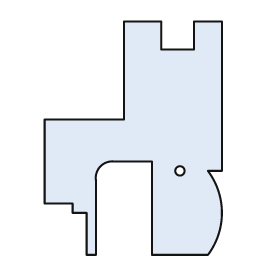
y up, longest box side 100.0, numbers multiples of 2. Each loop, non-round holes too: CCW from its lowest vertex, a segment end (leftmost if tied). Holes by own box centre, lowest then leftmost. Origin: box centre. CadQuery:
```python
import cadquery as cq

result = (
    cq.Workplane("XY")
    .moveTo(-20.0, -50.0)
    .lineTo(-16.0, -50.0)
    .lineTo(-16.0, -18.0)
    .threePointArc((-14.0, -12.0), (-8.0, -10.0))
    .lineTo(8.0, -10.0)
    .lineTo(8.0, -50.0)
    .lineTo(32.0, -50.0)
    .threePointArc((38.0, -32.0), (32.0, -14.0))
    .lineTo(38.0, -14.0)
    .lineTo(38.0, 50.0)
    .lineTo(26.0, 50.0)
    .lineTo(26.0, 38.0)
    .lineTo(12.0, 38.0)
    .lineTo(12.0, 50.0)
    .lineTo(-4.0, 50.0)
    .lineTo(-4.0, 8.0)
    .lineTo(-38.0, 8.0)
    .lineTo(-38.0, -28.0)
    .lineTo(-26.0, -28.0)
    .lineTo(-26.0, -32.0)
    .lineTo(-20.0, -32.0)
    .close()
    .moveTo(20.0, -14.0)
    .circle(2.0)
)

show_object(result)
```